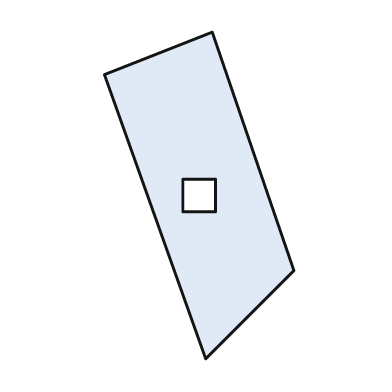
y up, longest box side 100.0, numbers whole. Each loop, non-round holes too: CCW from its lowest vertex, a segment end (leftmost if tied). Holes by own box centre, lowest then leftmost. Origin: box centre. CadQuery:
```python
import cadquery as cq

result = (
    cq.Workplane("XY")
    .moveTo(2.0, -50.0)
    .lineTo(29.0, -23.0)
    .lineTo(4.0, 50.0)
    .lineTo(-29.0, 37.0)
    .close()
    .moveTo(-5.0, -5.0)
    .lineTo(5.0, -5.0)
    .lineTo(5.0, 5.0)
    .lineTo(-5.0, 5.0)
    .close()
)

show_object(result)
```